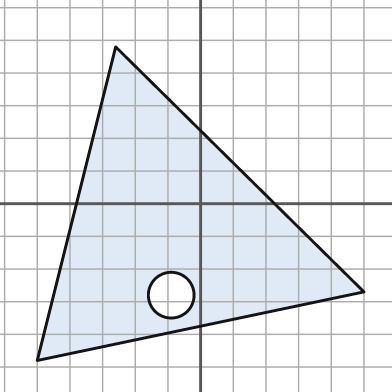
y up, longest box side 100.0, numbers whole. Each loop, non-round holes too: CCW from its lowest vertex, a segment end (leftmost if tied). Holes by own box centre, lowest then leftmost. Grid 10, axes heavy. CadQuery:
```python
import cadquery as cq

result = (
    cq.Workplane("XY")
    .moveTo(-50.0, -48.0)
    .lineTo(50.0, -27.0)
    .lineTo(-26.0, 48.0)
    .close()
    .moveTo(-9.0, -28.0)
    .circle(7.0)
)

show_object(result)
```